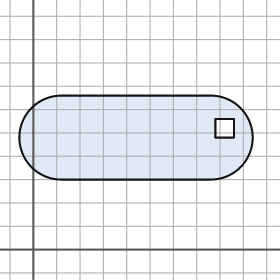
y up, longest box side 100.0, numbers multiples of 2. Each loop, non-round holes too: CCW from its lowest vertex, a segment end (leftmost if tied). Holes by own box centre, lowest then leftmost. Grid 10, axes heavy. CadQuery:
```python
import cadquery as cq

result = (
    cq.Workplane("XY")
    .moveTo(12.0, 30.0)
    .lineTo(76.0, 30.0)
    .threePointArc((94.0, 48.0), (76.0, 66.0))
    .lineTo(12.0, 66.0)
    .threePointArc((-6.0, 48.0), (12.0, 30.0))
    .close()
    .moveTo(78.0, 48.0)
    .lineTo(86.0, 48.0)
    .lineTo(86.0, 56.0)
    .lineTo(78.0, 56.0)
    .close()
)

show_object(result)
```